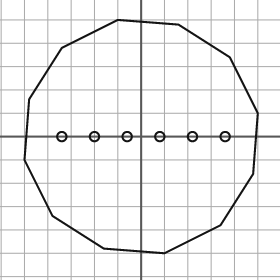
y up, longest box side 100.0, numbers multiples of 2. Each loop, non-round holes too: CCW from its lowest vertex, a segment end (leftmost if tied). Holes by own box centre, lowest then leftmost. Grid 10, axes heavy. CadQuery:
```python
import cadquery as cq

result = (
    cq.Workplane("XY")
    .moveTo(10.0, -50.0)
    .lineTo(34.0, -38.0)
    .lineTo(48.0, -16.0)
    .lineTo(50.0, 10.0)
    .lineTo(38.0, 34.0)
    .lineTo(16.0, 48.0)
    .lineTo(-10.0, 50.0)
    .lineTo(-34.0, 38.0)
    .lineTo(-48.0, 16.0)
    .lineTo(-50.0, -10.0)
    .lineTo(-38.0, -34.0)
    .lineTo(-16.0, -48.0)
    .close()
    .moveTo(-34.0, 0.0)
    .circle(2.0)
    .moveTo(-20.0, 0.0)
    .circle(2.0)
    .moveTo(-6.0, 0.0)
    .circle(2.0)
    .moveTo(8.0, 0.0)
    .circle(2.0)
    .moveTo(22.0, 0.0)
    .circle(2.0)
    .moveTo(36.0, 0.0)
    .circle(2.0)
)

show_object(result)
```